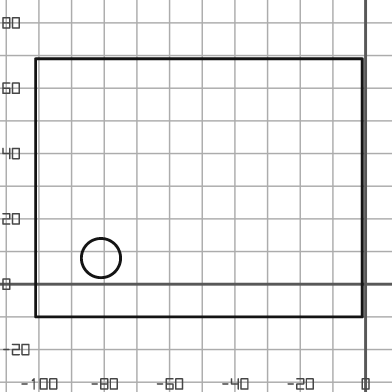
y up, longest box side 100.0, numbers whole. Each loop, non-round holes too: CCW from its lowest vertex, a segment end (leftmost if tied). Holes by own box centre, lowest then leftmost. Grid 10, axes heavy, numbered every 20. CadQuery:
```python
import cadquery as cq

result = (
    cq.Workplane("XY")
    .moveTo(-101.0, -10.0)
    .lineTo(-1.0, -10.0)
    .lineTo(-1.0, 69.0)
    .lineTo(-101.0, 69.0)
    .close()
    .moveTo(-81.0, 8.0)
    .circle(6.0)
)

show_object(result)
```